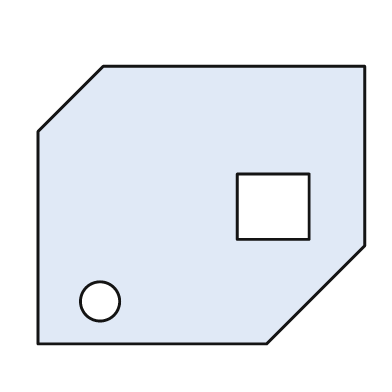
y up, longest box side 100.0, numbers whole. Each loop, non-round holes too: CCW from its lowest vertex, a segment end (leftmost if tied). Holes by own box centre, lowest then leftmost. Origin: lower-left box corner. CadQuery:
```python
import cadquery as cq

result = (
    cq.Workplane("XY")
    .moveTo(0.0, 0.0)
    .lineTo(70.0, 0.0)
    .lineTo(100.0, 30.0)
    .lineTo(100.0, 85.0)
    .lineTo(20.0, 85.0)
    .lineTo(0.0, 65.0)
    .close()
    .moveTo(19.0, 13.0)
    .circle(6.0)
    .moveTo(61.0, 32.0)
    .lineTo(83.0, 32.0)
    .lineTo(83.0, 52.0)
    .lineTo(61.0, 52.0)
    .close()
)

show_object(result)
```